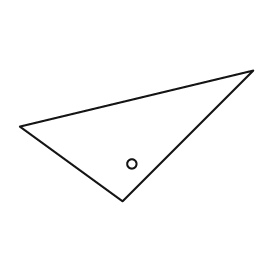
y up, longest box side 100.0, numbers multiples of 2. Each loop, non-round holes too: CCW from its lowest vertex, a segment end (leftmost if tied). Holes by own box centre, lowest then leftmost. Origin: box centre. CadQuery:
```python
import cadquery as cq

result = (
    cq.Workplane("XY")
    .moveTo(-6.0, -28.0)
    .lineTo(50.0, 28.0)
    .lineTo(-50.0, 4.0)
    .close()
    .moveTo(-2.0, -12.0)
    .circle(2.0)
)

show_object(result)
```